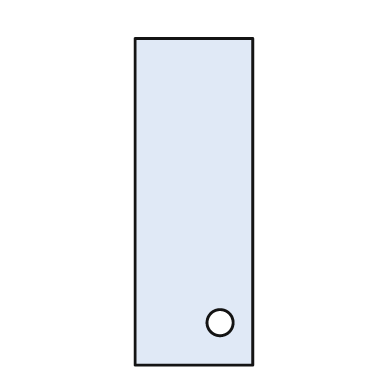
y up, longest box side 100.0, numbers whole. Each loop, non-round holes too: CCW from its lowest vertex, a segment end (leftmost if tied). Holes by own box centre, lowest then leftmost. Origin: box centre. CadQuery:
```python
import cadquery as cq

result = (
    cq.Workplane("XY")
    .moveTo(-18.0, -50.0)
    .lineTo(18.0, -50.0)
    .lineTo(18.0, 50.0)
    .lineTo(-18.0, 50.0)
    .close()
    .moveTo(8.0, -37.0)
    .circle(4.0)
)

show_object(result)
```